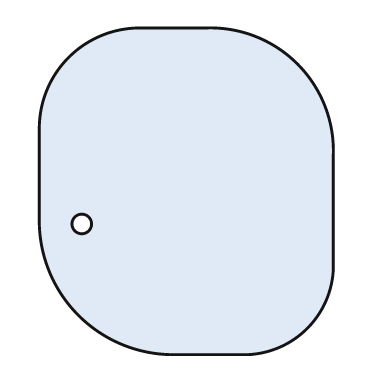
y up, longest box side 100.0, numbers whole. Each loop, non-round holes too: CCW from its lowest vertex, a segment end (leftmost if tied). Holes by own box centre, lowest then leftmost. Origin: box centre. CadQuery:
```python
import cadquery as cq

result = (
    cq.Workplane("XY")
    .moveTo(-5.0, -50.0)
    .lineTo(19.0, -50.0)
    .threePointArc((37.0, -42.0), (45.0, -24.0))
    .lineTo(45.0, 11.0)
    .threePointArc((34.0, 39.0), (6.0, 50.0))
    .lineTo(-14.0, 50.0)
    .threePointArc((-36.0, 41.0), (-45.0, 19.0))
    .lineTo(-45.0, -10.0)
    .threePointArc((-33.0, -38.0), (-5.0, -50.0))
    .close()
    .moveTo(-32.0, -10.0)
    .circle(3.0)
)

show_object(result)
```